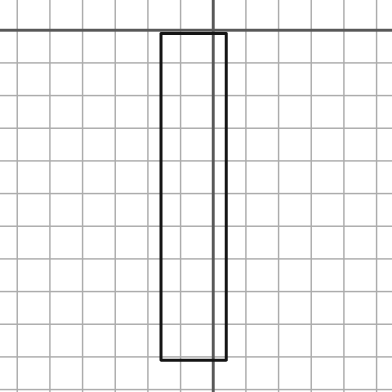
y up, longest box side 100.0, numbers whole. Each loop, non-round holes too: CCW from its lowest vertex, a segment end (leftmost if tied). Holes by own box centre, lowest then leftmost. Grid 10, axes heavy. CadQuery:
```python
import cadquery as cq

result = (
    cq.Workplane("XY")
    .moveTo(-16.0, -101.0)
    .lineTo(4.0, -101.0)
    .lineTo(4.0, -1.0)
    .lineTo(-16.0, -1.0)
    .close()
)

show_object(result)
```